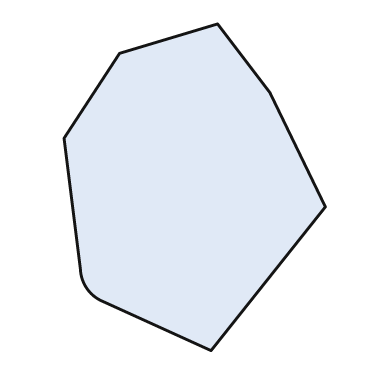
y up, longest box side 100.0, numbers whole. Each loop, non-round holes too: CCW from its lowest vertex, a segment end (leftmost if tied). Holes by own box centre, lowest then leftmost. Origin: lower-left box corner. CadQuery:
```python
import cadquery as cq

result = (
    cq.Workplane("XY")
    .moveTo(45.0, 0.0)
    .lineTo(80.0, 44.0)
    .lineTo(63.0, 79.0)
    .lineTo(47.0, 100.0)
    .lineTo(17.0, 91.0)
    .lineTo(0.0, 65.0)
    .lineTo(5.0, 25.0)
    .threePointArc((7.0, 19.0), (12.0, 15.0))
    .close()
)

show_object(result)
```